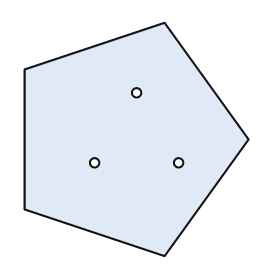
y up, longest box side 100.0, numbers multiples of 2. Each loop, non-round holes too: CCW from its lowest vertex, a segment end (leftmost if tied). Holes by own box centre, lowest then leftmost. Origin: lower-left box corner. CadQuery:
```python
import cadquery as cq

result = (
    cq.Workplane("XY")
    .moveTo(60.0, 0.0)
    .lineTo(96.0, 50.0)
    .lineTo(60.0, 100.0)
    .lineTo(0.0, 80.0)
    .lineTo(0.0, 20.0)
    .close()
    .moveTo(30.0, 40.0)
    .circle(2.0)
    .moveTo(66.0, 40.0)
    .circle(2.0)
    .moveTo(48.0, 70.0)
    .circle(2.0)
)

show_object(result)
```